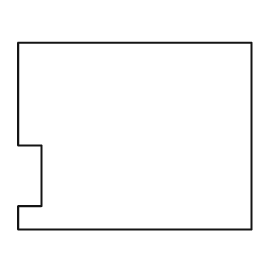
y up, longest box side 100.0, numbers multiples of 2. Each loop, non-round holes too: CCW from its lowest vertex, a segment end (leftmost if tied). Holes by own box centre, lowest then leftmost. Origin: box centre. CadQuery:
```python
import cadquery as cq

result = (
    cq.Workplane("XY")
    .moveTo(-50.0, -40.0)
    .lineTo(50.0, -40.0)
    .lineTo(50.0, 40.0)
    .lineTo(-50.0, 40.0)
    .lineTo(-50.0, -4.0)
    .lineTo(-40.0, -4.0)
    .lineTo(-40.0, -30.0)
    .lineTo(-50.0, -30.0)
    .close()
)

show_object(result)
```